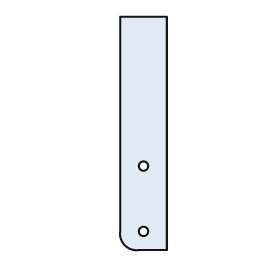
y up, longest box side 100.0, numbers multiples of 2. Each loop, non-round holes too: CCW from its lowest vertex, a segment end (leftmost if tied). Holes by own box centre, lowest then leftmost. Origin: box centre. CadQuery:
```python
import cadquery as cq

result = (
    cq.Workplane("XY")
    .moveTo(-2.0, -50.0)
    .lineTo(10.0, -50.0)
    .lineTo(10.0, 50.0)
    .lineTo(-10.0, 50.0)
    .lineTo(-10.0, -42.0)
    .threePointArc((-8.0, -48.0), (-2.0, -50.0))
    .close()
    .moveTo(0.0, -42.0)
    .circle(2.0)
    .moveTo(0.0, -14.0)
    .circle(2.0)
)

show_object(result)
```